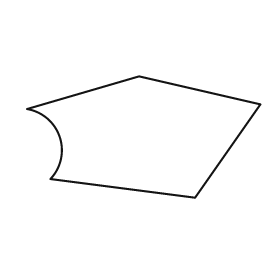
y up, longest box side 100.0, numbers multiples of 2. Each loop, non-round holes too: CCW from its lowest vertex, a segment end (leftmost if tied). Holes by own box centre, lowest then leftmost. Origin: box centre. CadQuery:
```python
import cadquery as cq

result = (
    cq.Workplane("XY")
    .moveTo(22.0, -26.0)
    .lineTo(50.0, 14.0)
    .lineTo(-2.0, 26.0)
    .lineTo(-50.0, 12.0)
    .threePointArc((-36.0, 0.0), (-40.0, -18.0))
    .close()
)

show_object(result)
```